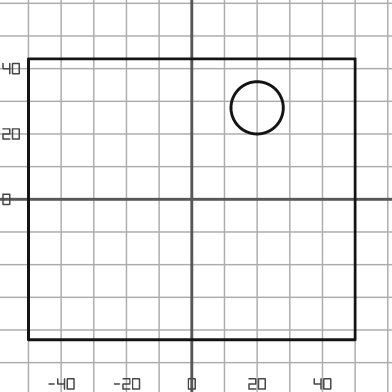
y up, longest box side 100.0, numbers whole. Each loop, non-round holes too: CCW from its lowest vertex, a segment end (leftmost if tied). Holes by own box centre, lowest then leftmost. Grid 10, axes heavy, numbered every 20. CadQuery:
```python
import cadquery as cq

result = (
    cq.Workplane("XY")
    .moveTo(-50.0, -43.0)
    .lineTo(50.0, -43.0)
    .lineTo(50.0, 43.0)
    .lineTo(-50.0, 43.0)
    .close()
    .moveTo(20.0, 28.0)
    .circle(8.0)
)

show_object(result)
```